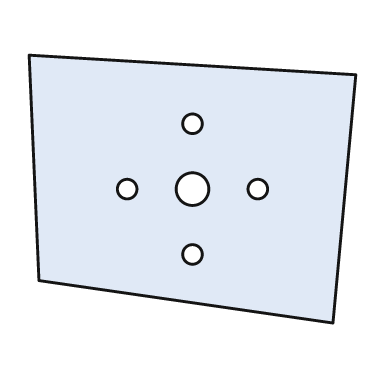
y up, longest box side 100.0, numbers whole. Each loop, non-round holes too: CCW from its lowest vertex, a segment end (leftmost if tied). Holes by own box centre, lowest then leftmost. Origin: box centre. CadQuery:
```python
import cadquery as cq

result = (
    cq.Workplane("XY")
    .moveTo(43.0, -41.0)
    .lineTo(50.0, 35.0)
    .lineTo(-50.0, 41.0)
    .lineTo(-47.0, -28.0)
    .close()
    .moveTo(0.0, -20.0)
    .circle(3.0)
    .moveTo(-20.0, 0.0)
    .circle(3.0)
    .moveTo(0.0, 0.0)
    .circle(5.0)
    .moveTo(20.0, 0.0)
    .circle(3.0)
    .moveTo(0.0, 20.0)
    .circle(3.0)
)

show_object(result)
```